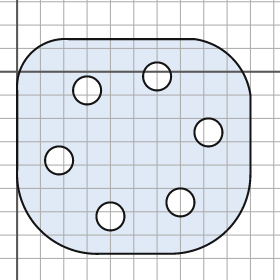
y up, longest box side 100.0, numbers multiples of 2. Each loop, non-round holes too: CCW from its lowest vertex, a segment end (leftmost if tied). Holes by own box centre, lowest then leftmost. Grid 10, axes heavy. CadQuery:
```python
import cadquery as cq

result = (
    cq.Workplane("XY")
    .moveTo(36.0, -78.0)
    .lineTo(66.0, -78.0)
    .threePointArc((90.0, -68.0), (100.0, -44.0))
    .lineTo(100.0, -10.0)
    .threePointArc((92.0, 6.0), (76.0, 14.0))
    .lineTo(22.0, 14.0)
    .threePointArc((6.0, 8.0), (0.0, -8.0))
    .lineTo(0.0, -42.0)
    .threePointArc((10.0, -68.0), (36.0, -78.0))
    .close()
    .moveTo(40.0, -62.0)
    .circle(6.0)
    .moveTo(70.0, -56.0)
    .circle(6.0)
    .moveTo(18.0, -38.0)
    .circle(6.0)
    .moveTo(82.0, -26.0)
    .circle(6.0)
    .moveTo(30.0, -8.0)
    .circle(6.0)
    .moveTo(60.0, -2.0)
    .circle(6.0)
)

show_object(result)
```